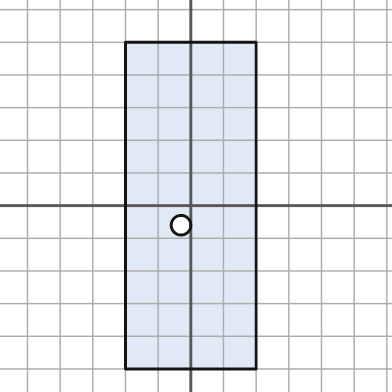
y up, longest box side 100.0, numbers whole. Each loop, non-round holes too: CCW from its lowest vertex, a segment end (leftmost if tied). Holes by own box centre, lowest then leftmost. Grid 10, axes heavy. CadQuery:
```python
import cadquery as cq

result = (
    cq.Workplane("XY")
    .moveTo(-20.0, -50.0)
    .lineTo(20.0, -50.0)
    .lineTo(20.0, 50.0)
    .lineTo(-20.0, 50.0)
    .close()
    .moveTo(-3.0, -6.0)
    .circle(3.0)
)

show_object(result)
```